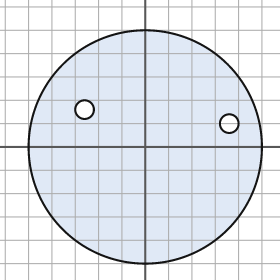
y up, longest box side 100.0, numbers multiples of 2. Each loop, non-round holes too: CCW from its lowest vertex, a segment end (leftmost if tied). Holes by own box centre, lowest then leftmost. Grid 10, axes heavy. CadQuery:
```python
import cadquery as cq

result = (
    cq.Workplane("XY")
    .moveTo(0.0, 0.0)
    .circle(50.0)
    .moveTo(36.0, 10.0)
    .circle(4.0)
    .moveTo(-26.0, 16.0)
    .circle(4.0)
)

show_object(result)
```